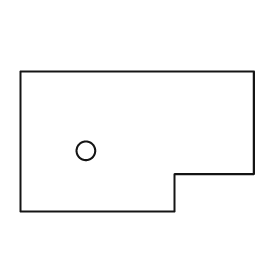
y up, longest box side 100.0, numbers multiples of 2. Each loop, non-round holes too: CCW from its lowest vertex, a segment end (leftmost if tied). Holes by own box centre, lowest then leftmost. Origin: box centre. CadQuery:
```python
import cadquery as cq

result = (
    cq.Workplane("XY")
    .moveTo(-50.0, -30.0)
    .lineTo(16.0, -30.0)
    .lineTo(16.0, -14.0)
    .lineTo(50.0, -14.0)
    .lineTo(50.0, 30.0)
    .lineTo(-50.0, 30.0)
    .close()
    .moveTo(-22.0, -4.0)
    .circle(4.0)
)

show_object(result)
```